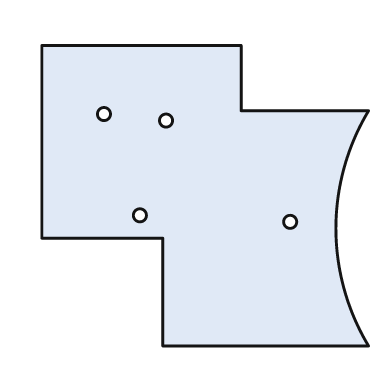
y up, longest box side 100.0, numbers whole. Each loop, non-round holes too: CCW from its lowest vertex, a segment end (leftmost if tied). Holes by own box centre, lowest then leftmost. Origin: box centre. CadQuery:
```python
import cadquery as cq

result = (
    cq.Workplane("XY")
    .moveTo(-13.0, -46.0)
    .lineTo(50.0, -46.0)
    .threePointArc((40.0, -10.0), (50.0, 26.0))
    .lineTo(11.0, 26.0)
    .lineTo(11.0, 46.0)
    .lineTo(-50.0, 46.0)
    .lineTo(-50.0, -13.0)
    .lineTo(-13.0, -13.0)
    .close()
    .moveTo(26.0, -8.0)
    .circle(2.0)
    .moveTo(-20.0, -6.0)
    .circle(2.0)
    .moveTo(-12.0, 23.0)
    .circle(2.0)
    .moveTo(-31.0, 25.0)
    .circle(2.0)
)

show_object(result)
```